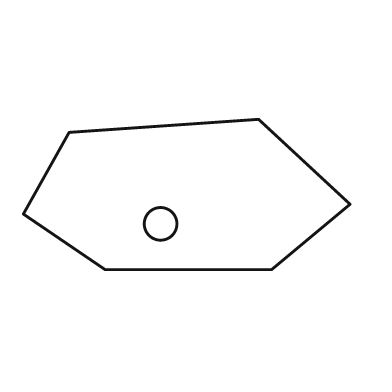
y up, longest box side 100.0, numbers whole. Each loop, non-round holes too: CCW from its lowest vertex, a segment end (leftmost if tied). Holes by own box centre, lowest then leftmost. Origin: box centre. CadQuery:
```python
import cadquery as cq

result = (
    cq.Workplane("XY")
    .moveTo(-25.0, -23.0)
    .lineTo(26.0, -23.0)
    .lineTo(50.0, -3.0)
    .lineTo(22.0, 23.0)
    .lineTo(-36.0, 19.0)
    .lineTo(-50.0, -6.0)
    .close()
    .moveTo(-8.0, -9.0)
    .circle(5.0)
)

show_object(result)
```